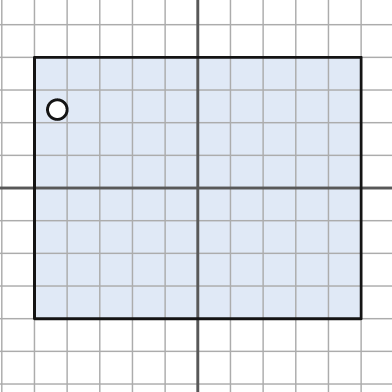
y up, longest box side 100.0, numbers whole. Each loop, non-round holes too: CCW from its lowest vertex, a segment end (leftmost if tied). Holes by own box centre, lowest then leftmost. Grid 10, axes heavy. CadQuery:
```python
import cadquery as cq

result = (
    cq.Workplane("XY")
    .moveTo(-50.0, -40.0)
    .lineTo(50.0, -40.0)
    .lineTo(50.0, 40.0)
    .lineTo(-50.0, 40.0)
    .close()
    .moveTo(-43.0, 24.0)
    .circle(3.0)
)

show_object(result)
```